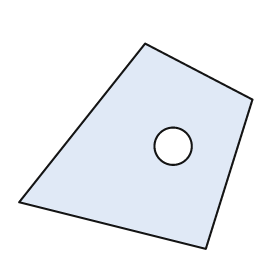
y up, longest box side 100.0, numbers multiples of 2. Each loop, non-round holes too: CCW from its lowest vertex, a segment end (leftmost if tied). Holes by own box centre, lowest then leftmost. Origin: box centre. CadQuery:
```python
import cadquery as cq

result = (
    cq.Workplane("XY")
    .moveTo(30.0, -44.0)
    .lineTo(50.0, 20.0)
    .lineTo(4.0, 44.0)
    .lineTo(-50.0, -24.0)
    .close()
    .moveTo(16.0, 0.0)
    .circle(8.0)
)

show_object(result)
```